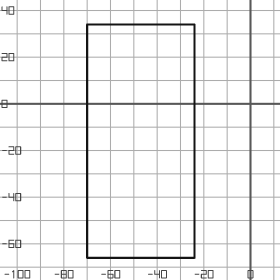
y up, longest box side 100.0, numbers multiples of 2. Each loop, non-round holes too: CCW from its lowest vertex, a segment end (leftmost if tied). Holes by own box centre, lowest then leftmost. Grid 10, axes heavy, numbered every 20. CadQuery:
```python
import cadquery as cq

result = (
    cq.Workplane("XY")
    .moveTo(-70.0, -66.0)
    .lineTo(-24.0, -66.0)
    .lineTo(-24.0, 34.0)
    .lineTo(-70.0, 34.0)
    .close()
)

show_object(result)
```